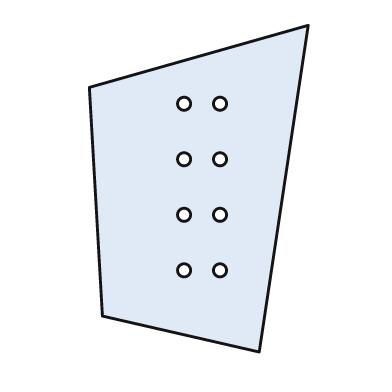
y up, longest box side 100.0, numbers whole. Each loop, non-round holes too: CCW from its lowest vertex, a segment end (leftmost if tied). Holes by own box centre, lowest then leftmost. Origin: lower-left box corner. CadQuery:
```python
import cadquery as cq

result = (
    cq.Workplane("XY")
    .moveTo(52.0, 0.0)
    .lineTo(67.0, 100.0)
    .lineTo(0.0, 81.0)
    .lineTo(4.0, 11.0)
    .close()
    .moveTo(29.0, 25.0)
    .circle(2.0)
    .moveTo(40.0, 25.0)
    .circle(2.0)
    .moveTo(29.0, 42.0)
    .circle(2.0)
    .moveTo(40.0, 42.0)
    .circle(2.0)
    .moveTo(29.0, 59.0)
    .circle(2.0)
    .moveTo(40.0, 59.0)
    .circle(2.0)
    .moveTo(29.0, 76.0)
    .circle(2.0)
    .moveTo(40.0, 76.0)
    .circle(2.0)
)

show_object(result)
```